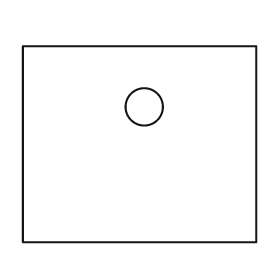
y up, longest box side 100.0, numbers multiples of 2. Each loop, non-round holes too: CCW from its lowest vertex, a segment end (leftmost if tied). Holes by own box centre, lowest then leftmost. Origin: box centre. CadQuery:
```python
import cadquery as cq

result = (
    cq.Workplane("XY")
    .moveTo(-50.0, -42.0)
    .lineTo(50.0, -42.0)
    .lineTo(50.0, 42.0)
    .lineTo(-50.0, 42.0)
    .close()
    .moveTo(2.0, 16.0)
    .circle(8.0)
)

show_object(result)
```